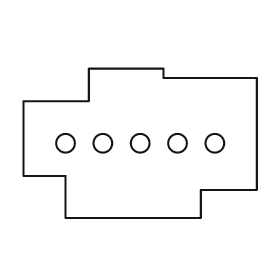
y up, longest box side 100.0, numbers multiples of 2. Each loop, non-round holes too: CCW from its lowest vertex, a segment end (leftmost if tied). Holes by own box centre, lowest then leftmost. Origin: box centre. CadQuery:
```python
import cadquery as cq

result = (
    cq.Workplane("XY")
    .moveTo(-32.0, -32.0)
    .lineTo(26.0, -32.0)
    .lineTo(26.0, -20.0)
    .lineTo(50.0, -20.0)
    .lineTo(50.0, 28.0)
    .lineTo(10.0, 28.0)
    .lineTo(10.0, 32.0)
    .lineTo(-22.0, 32.0)
    .lineTo(-22.0, 18.0)
    .lineTo(-50.0, 18.0)
    .lineTo(-50.0, -14.0)
    .lineTo(-32.0, -14.0)
    .close()
    .moveTo(-32.0, 0.0)
    .circle(4.0)
    .moveTo(-16.0, 0.0)
    .circle(4.0)
    .moveTo(0.0, 0.0)
    .circle(4.0)
    .moveTo(16.0, 0.0)
    .circle(4.0)
    .moveTo(32.0, 0.0)
    .circle(4.0)
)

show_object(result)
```